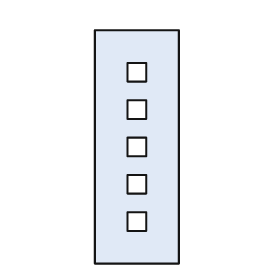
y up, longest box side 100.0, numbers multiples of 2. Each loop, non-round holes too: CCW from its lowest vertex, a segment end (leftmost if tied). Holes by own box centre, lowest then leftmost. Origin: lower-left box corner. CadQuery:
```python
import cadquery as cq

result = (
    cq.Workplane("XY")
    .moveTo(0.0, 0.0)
    .lineTo(36.0, 0.0)
    .lineTo(36.0, 100.0)
    .lineTo(0.0, 100.0)
    .close()
    .moveTo(14.0, 14.0)
    .lineTo(22.0, 14.0)
    .lineTo(22.0, 22.0)
    .lineTo(14.0, 22.0)
    .close()
    .moveTo(14.0, 30.0)
    .lineTo(22.0, 30.0)
    .lineTo(22.0, 38.0)
    .lineTo(14.0, 38.0)
    .close()
    .moveTo(14.0, 46.0)
    .lineTo(22.0, 46.0)
    .lineTo(22.0, 54.0)
    .lineTo(14.0, 54.0)
    .close()
    .moveTo(14.0, 62.0)
    .lineTo(22.0, 62.0)
    .lineTo(22.0, 70.0)
    .lineTo(14.0, 70.0)
    .close()
    .moveTo(14.0, 78.0)
    .lineTo(22.0, 78.0)
    .lineTo(22.0, 86.0)
    .lineTo(14.0, 86.0)
    .close()
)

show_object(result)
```